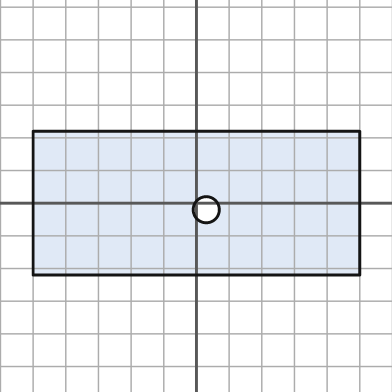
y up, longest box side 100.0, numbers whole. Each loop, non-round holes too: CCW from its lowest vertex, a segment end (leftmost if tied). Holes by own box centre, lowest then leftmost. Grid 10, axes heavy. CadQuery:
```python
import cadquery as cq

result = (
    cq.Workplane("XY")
    .moveTo(-50.0, -22.0)
    .lineTo(50.0, -22.0)
    .lineTo(50.0, 22.0)
    .lineTo(-50.0, 22.0)
    .close()
    .moveTo(3.0, -2.0)
    .circle(4.0)
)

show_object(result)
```